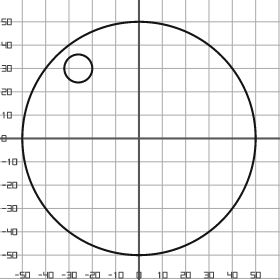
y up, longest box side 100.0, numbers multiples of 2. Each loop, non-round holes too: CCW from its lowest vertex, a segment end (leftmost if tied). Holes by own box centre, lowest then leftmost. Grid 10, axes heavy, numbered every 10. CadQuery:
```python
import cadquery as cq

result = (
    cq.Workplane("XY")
    .moveTo(0.0, 0.0)
    .circle(50.0)
    .moveTo(-26.0, 30.0)
    .circle(6.0)
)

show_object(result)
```